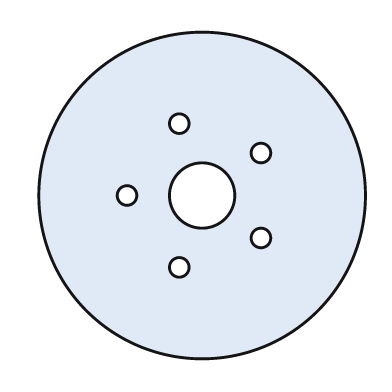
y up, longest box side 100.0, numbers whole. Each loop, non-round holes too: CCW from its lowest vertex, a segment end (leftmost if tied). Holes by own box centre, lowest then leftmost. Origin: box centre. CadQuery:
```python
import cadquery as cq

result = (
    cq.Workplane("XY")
    .moveTo(0.0, 0.0)
    .circle(50.0)
    .moveTo(-7.0, -22.0)
    .circle(3.0)
    .moveTo(18.0, -13.0)
    .circle(3.0)
    .moveTo(-23.0, 0.0)
    .circle(3.0)
    .moveTo(0.0, 0.0)
    .circle(10.0)
    .moveTo(18.0, 13.0)
    .circle(3.0)
    .moveTo(-7.0, 22.0)
    .circle(3.0)
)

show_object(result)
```